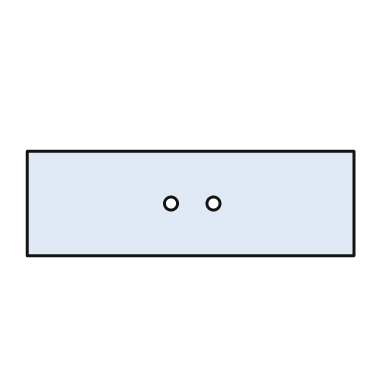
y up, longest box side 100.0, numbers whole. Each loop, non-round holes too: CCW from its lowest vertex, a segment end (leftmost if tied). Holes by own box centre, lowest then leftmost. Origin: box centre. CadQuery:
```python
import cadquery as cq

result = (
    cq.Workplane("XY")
    .moveTo(-50.0, -16.0)
    .lineTo(50.0, -16.0)
    .lineTo(50.0, 16.0)
    .lineTo(-50.0, 16.0)
    .close()
    .moveTo(-6.0, 0.0)
    .circle(2.0)
    .moveTo(7.0, 0.0)
    .circle(2.0)
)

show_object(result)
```